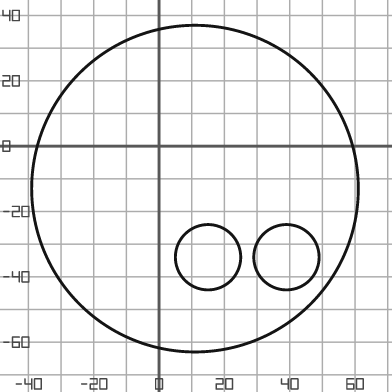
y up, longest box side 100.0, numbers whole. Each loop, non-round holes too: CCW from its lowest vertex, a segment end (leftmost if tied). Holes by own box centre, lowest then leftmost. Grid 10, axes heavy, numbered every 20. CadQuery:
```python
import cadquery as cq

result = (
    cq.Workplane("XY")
    .moveTo(11.0, -13.0)
    .circle(50.0)
    .moveTo(15.0, -34.0)
    .circle(10.0)
    .moveTo(39.0, -34.0)
    .circle(10.0)
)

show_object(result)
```